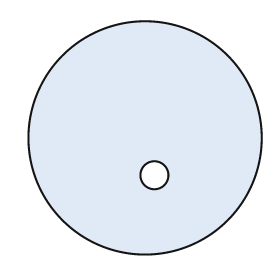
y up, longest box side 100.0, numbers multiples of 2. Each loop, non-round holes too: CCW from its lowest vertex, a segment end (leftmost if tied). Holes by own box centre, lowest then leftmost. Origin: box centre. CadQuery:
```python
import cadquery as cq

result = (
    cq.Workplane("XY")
    .moveTo(0.0, 0.0)
    .circle(50.0)
    .moveTo(4.0, -16.0)
    .circle(6.0)
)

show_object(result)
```